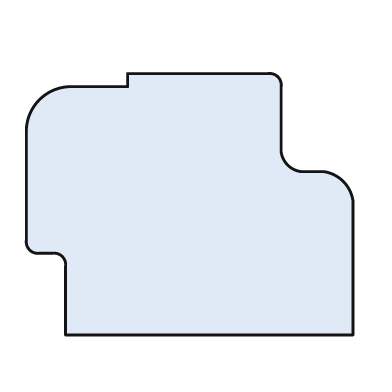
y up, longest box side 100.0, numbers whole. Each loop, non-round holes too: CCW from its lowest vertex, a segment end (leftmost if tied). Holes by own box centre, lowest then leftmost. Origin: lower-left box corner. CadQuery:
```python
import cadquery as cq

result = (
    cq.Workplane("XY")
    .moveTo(12.0, 0.0)
    .lineTo(100.0, 0.0)
    .lineTo(100.0, 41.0)
    .threePointArc((97.0, 47.0), (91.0, 50.0))
    .lineTo(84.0, 50.0)
    .threePointArc((80.0, 52.0), (78.0, 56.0))
    .lineTo(78.0, 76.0)
    .threePointArc((77.0, 79.0), (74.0, 80.0))
    .lineTo(31.0, 80.0)
    .lineTo(31.0, 76.0)
    .lineTo(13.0, 76.0)
    .threePointArc((4.0, 72.0), (0.0, 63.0))
    .lineTo(0.0, 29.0)
    .threePointArc((1.0, 26.0), (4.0, 25.0))
    .lineTo(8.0, 25.0)
    .threePointArc((11.0, 24.0), (12.0, 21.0))
    .close()
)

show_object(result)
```